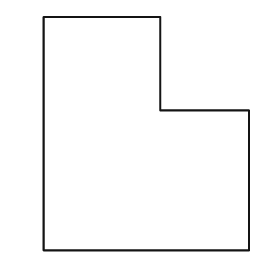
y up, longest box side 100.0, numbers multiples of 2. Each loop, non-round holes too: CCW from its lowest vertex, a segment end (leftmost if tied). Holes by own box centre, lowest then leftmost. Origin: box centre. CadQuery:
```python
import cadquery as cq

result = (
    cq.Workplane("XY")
    .moveTo(-44.0, -50.0)
    .lineTo(44.0, -50.0)
    .lineTo(44.0, 10.0)
    .lineTo(6.0, 10.0)
    .lineTo(6.0, 50.0)
    .lineTo(-44.0, 50.0)
    .close()
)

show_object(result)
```